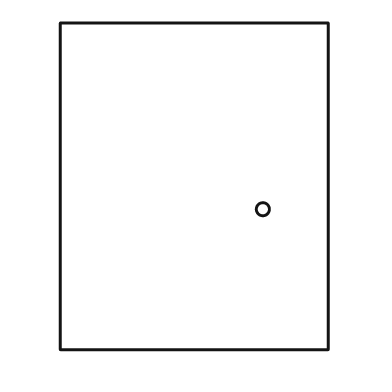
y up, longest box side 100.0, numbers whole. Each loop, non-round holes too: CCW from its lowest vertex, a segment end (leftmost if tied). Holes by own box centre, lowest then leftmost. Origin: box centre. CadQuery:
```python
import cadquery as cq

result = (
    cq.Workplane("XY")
    .moveTo(-41.0, -50.0)
    .lineTo(41.0, -50.0)
    .lineTo(41.0, 50.0)
    .lineTo(-41.0, 50.0)
    .close()
    .moveTo(21.0, -7.0)
    .circle(2.0)
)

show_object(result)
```